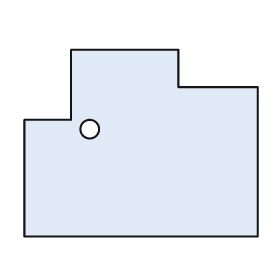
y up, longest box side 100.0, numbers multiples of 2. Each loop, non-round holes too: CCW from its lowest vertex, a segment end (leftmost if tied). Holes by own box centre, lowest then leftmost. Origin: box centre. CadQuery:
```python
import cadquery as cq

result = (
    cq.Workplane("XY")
    .moveTo(-50.0, -40.0)
    .lineTo(50.0, -40.0)
    .lineTo(50.0, 24.0)
    .lineTo(16.0, 24.0)
    .lineTo(16.0, 40.0)
    .lineTo(-30.0, 40.0)
    .lineTo(-30.0, 10.0)
    .lineTo(-50.0, 10.0)
    .close()
    .moveTo(-22.0, 6.0)
    .circle(4.0)
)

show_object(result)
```